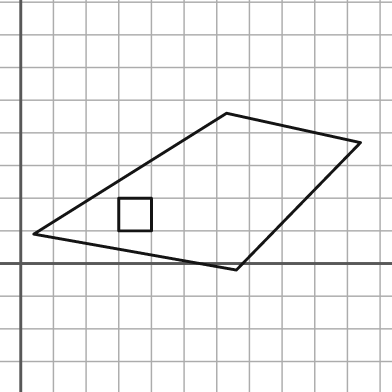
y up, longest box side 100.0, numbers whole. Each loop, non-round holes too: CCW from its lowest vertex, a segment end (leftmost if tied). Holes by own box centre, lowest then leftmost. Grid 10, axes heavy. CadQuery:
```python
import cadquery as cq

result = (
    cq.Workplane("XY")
    .moveTo(66.0, -2.0)
    .lineTo(104.0, 37.0)
    .lineTo(63.0, 46.0)
    .lineTo(4.0, 9.0)
    .close()
    .moveTo(30.0, 10.0)
    .lineTo(40.0, 10.0)
    .lineTo(40.0, 20.0)
    .lineTo(30.0, 20.0)
    .close()
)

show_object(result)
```